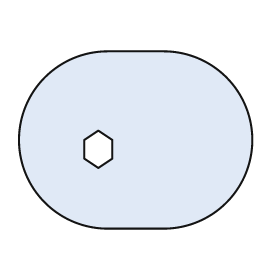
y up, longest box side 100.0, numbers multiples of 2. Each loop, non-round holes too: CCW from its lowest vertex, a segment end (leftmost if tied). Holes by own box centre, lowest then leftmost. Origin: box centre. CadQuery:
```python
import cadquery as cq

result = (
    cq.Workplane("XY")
    .moveTo(-12.0, -38.0)
    .lineTo(12.0, -38.0)
    .threePointArc((50.0, 0.0), (12.0, 38.0))
    .lineTo(-12.0, 38.0)
    .threePointArc((-50.0, 0.0), (-12.0, -38.0))
    .close()
    .moveTo(-16.0, -12.0)
    .lineTo(-10.0, -8.0)
    .lineTo(-10.0, 0.0)
    .lineTo(-16.0, 4.0)
    .lineTo(-22.0, 0.0)
    .lineTo(-22.0, -8.0)
    .close()
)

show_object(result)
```